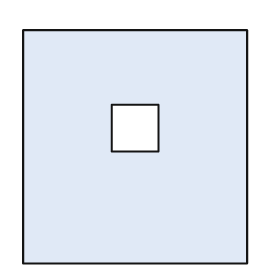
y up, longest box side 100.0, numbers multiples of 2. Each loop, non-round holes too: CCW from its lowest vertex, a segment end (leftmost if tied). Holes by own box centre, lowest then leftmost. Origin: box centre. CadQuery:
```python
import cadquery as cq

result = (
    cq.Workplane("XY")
    .moveTo(-48.0, -50.0)
    .lineTo(48.0, -50.0)
    .lineTo(48.0, 50.0)
    .lineTo(-48.0, 50.0)
    .close()
    .moveTo(-10.0, -2.0)
    .lineTo(10.0, -2.0)
    .lineTo(10.0, 18.0)
    .lineTo(-10.0, 18.0)
    .close()
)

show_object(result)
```